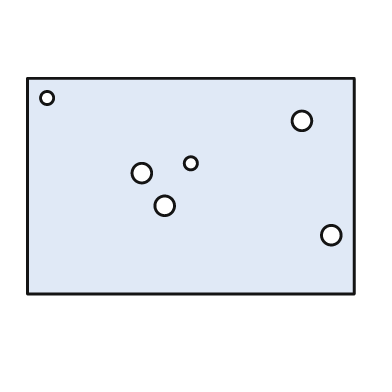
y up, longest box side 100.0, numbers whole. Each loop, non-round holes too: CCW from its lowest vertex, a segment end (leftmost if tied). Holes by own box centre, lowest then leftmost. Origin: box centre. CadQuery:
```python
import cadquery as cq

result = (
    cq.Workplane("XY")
    .moveTo(-50.0, -33.0)
    .lineTo(50.0, -33.0)
    .lineTo(50.0, 33.0)
    .lineTo(-50.0, 33.0)
    .close()
    .moveTo(43.0, -15.0)
    .circle(3.0)
    .moveTo(-8.0, -6.0)
    .circle(3.0)
    .moveTo(-15.0, 4.0)
    .circle(3.0)
    .moveTo(0.0, 7.0)
    .circle(2.0)
    .moveTo(34.0, 20.0)
    .circle(3.0)
    .moveTo(-44.0, 27.0)
    .circle(2.0)
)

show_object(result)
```